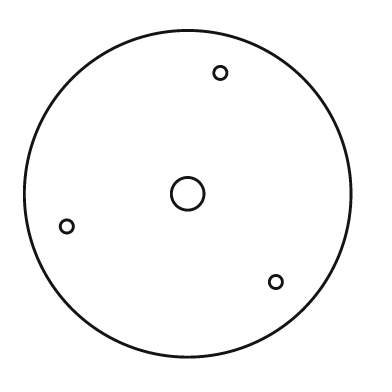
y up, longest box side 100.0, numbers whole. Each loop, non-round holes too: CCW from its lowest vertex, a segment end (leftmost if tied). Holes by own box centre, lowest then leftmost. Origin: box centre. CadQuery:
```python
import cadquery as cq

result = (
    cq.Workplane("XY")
    .moveTo(0.0, 0.0)
    .circle(50.0)
    .moveTo(27.0, -27.0)
    .circle(2.0)
    .moveTo(-37.0, -10.0)
    .circle(2.0)
    .moveTo(0.0, 0.0)
    .circle(5.0)
    .moveTo(10.0, 37.0)
    .circle(2.0)
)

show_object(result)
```